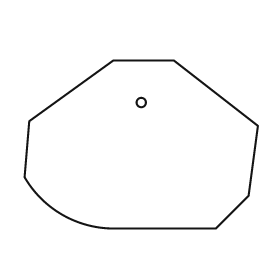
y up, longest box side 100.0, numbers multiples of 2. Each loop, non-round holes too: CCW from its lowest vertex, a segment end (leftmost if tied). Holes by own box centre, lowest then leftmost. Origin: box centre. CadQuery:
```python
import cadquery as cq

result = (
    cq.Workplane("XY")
    .moveTo(-12.0, -36.0)
    .lineTo(32.0, -36.0)
    .lineTo(46.0, -22.0)
    .lineTo(50.0, 8.0)
    .lineTo(14.0, 36.0)
    .lineTo(-12.0, 36.0)
    .lineTo(-48.0, 10.0)
    .lineTo(-50.0, -14.0)
    .threePointArc((-34.0, -30.0), (-12.0, -36.0))
    .close()
    .moveTo(0.0, 18.0)
    .circle(2.0)
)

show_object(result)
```